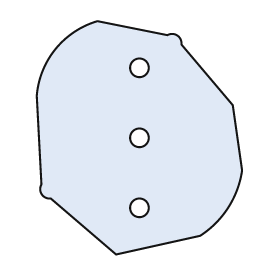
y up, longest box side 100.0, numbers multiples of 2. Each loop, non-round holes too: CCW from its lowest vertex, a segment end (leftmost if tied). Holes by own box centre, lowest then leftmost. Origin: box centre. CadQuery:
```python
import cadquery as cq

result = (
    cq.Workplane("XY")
    .moveTo(-10.0, -50.0)
    .lineTo(26.0, -42.0)
    .threePointArc((38.0, -30.0), (44.0, -14.0))
    .lineTo(40.0, 14.0)
    .lineTo(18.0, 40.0)
    .threePointArc((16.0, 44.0), (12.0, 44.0))
    .lineTo(-18.0, 50.0)
    .threePointArc((-36.0, 38.0), (-44.0, 18.0))
    .lineTo(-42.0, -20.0)
    .threePointArc((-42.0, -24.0), (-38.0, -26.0))
    .close()
    .moveTo(0.0, -30.0)
    .circle(4.0)
    .moveTo(0.0, 0.0)
    .circle(4.0)
    .moveTo(0.0, 30.0)
    .circle(4.0)
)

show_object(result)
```